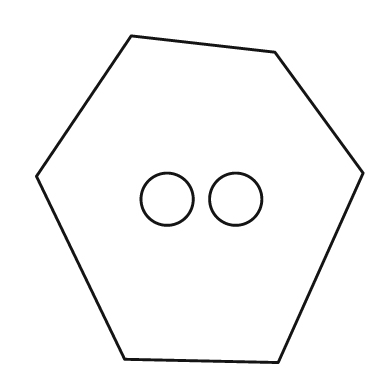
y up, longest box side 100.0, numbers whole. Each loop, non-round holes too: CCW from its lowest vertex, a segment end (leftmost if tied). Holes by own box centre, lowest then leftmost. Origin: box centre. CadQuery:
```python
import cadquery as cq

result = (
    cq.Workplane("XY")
    .moveTo(24.0, -50.0)
    .lineTo(50.0, 8.0)
    .lineTo(23.0, 45.0)
    .lineTo(-21.0, 50.0)
    .lineTo(-50.0, 7.0)
    .lineTo(-23.0, -49.0)
    .close()
    .moveTo(-10.0, 0.0)
    .circle(8.0)
    .moveTo(11.0, 0.0)
    .circle(8.0)
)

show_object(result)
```